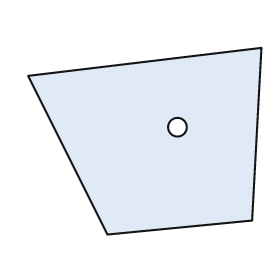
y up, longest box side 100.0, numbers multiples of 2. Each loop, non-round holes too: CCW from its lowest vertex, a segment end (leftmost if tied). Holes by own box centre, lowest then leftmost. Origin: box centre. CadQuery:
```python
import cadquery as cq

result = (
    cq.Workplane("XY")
    .moveTo(-16.0, -40.0)
    .lineTo(46.0, -34.0)
    .lineTo(50.0, 40.0)
    .lineTo(-50.0, 28.0)
    .close()
    .moveTo(14.0, 6.0)
    .circle(4.0)
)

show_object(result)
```